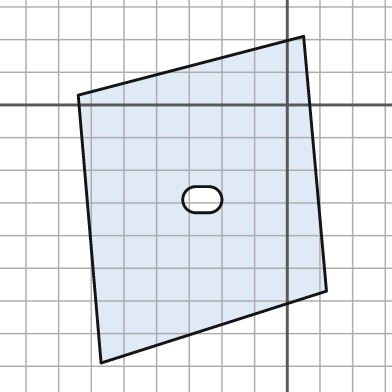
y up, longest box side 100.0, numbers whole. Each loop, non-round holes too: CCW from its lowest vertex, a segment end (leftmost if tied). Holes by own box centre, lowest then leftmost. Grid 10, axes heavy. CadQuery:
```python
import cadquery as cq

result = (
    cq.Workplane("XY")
    .moveTo(-57.0, -79.0)
    .lineTo(12.0, -57.0)
    .lineTo(5.0, 21.0)
    .lineTo(-64.0, 3.0)
    .close()
    .moveTo(-28.0, -33.0)
    .lineTo(-24.0, -33.0)
    .threePointArc((-20.0, -29.0), (-24.0, -25.0))
    .lineTo(-28.0, -25.0)
    .threePointArc((-32.0, -29.0), (-28.0, -33.0))
    .close()
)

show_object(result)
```